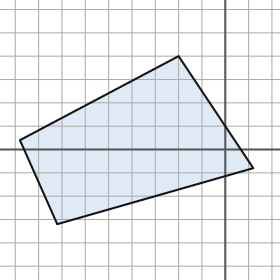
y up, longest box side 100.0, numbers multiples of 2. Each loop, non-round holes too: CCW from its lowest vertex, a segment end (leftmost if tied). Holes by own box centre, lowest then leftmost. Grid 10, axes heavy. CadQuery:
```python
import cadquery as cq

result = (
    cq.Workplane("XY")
    .moveTo(-72.0, -32.0)
    .lineTo(12.0, -8.0)
    .lineTo(-20.0, 40.0)
    .lineTo(-88.0, 4.0)
    .close()
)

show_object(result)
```